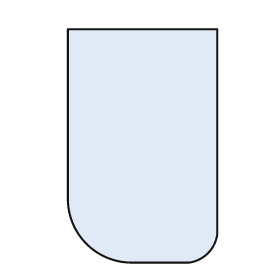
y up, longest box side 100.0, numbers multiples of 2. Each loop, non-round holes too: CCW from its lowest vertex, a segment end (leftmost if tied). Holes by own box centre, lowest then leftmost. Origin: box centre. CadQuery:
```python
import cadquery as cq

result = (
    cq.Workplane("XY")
    .moveTo(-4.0, -50.0)
    .lineTo(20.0, -50.0)
    .threePointArc((28.0, -46.0), (32.0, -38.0))
    .lineTo(32.0, 50.0)
    .lineTo(-32.0, 50.0)
    .lineTo(-32.0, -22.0)
    .threePointArc((-24.0, -42.0), (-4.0, -50.0))
    .close()
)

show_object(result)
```